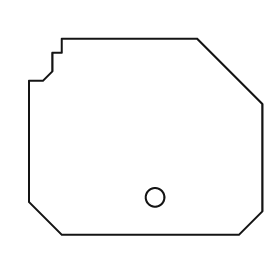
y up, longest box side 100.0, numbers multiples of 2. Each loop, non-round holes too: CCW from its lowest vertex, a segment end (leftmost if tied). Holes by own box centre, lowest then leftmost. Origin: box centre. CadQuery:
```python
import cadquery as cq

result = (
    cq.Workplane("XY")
    .moveTo(-36.0, -42.0)
    .lineTo(40.0, -42.0)
    .lineTo(50.0, -32.0)
    .lineTo(50.0, 14.0)
    .lineTo(22.0, 42.0)
    .lineTo(-36.0, 42.0)
    .lineTo(-36.0, 36.0)
    .lineTo(-40.0, 36.0)
    .lineTo(-40.0, 28.0)
    .lineTo(-44.0, 24.0)
    .lineTo(-50.0, 24.0)
    .lineTo(-50.0, -28.0)
    .close()
    .moveTo(4.0, -26.0)
    .circle(4.0)
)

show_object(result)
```